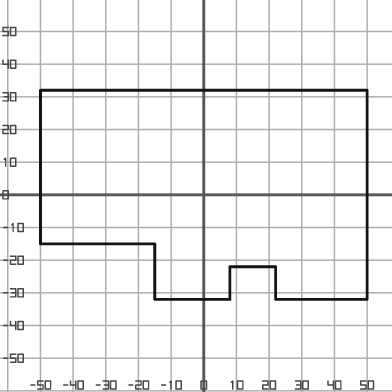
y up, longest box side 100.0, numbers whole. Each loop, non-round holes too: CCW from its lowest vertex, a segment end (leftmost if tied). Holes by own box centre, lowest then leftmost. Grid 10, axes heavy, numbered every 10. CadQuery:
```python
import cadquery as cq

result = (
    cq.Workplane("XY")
    .moveTo(-15.0, -32.0)
    .lineTo(8.0, -32.0)
    .lineTo(8.0, -22.0)
    .lineTo(22.0, -22.0)
    .lineTo(22.0, -32.0)
    .lineTo(50.0, -32.0)
    .lineTo(50.0, 32.0)
    .lineTo(-50.0, 32.0)
    .lineTo(-50.0, -15.0)
    .lineTo(-15.0, -15.0)
    .close()
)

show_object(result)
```